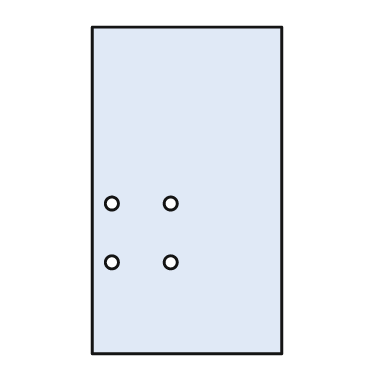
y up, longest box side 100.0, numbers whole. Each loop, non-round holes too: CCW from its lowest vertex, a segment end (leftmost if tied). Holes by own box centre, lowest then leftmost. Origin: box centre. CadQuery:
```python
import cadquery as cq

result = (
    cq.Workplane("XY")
    .moveTo(-29.0, -50.0)
    .lineTo(29.0, -50.0)
    .lineTo(29.0, 50.0)
    .lineTo(-29.0, 50.0)
    .close()
    .moveTo(-23.0, -22.0)
    .circle(2.0)
    .moveTo(-5.0, -22.0)
    .circle(2.0)
    .moveTo(-23.0, -4.0)
    .circle(2.0)
    .moveTo(-5.0, -4.0)
    .circle(2.0)
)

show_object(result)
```